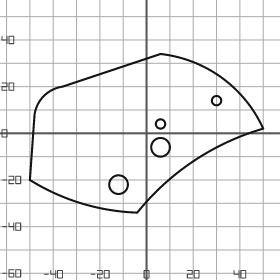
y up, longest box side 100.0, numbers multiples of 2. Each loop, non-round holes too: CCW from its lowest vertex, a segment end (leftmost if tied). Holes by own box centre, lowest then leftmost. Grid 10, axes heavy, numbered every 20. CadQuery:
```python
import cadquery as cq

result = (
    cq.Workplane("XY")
    .moveTo(-4.0, -34.0)
    .threePointArc((20.0, -12.0), (50.0, 2.0))
    .threePointArc((32.0, 24.0), (6.0, 34.0))
    .lineTo(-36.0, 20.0)
    .threePointArc((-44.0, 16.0), (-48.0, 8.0))
    .lineTo(-50.0, -20.0)
    .threePointArc((-28.0, -30.0), (-4.0, -34.0))
    .close()
    .moveTo(-12.0, -22.0)
    .circle(4.0)
    .moveTo(6.0, -6.0)
    .circle(4.0)
    .moveTo(6.0, 4.0)
    .circle(2.0)
    .moveTo(30.0, 14.0)
    .circle(2.0)
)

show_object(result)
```